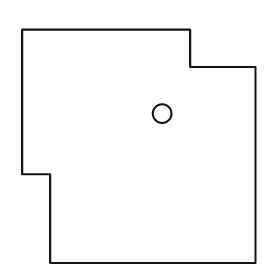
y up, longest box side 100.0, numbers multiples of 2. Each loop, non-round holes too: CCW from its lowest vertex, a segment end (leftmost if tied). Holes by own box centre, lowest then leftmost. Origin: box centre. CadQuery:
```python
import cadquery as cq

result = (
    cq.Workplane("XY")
    .moveTo(-38.0, -50.0)
    .lineTo(50.0, -50.0)
    .lineTo(50.0, 34.0)
    .lineTo(22.0, 34.0)
    .lineTo(22.0, 50.0)
    .lineTo(-50.0, 50.0)
    .lineTo(-50.0, -12.0)
    .lineTo(-38.0, -12.0)
    .close()
    .moveTo(10.0, 14.0)
    .circle(4.0)
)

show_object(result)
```